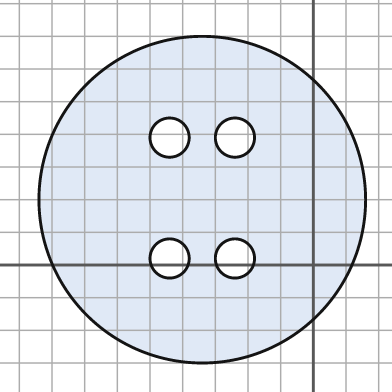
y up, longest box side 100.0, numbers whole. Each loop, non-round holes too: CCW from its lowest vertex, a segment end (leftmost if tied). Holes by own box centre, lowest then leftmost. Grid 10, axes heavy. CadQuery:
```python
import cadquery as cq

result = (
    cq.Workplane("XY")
    .moveTo(-34.0, 20.0)
    .circle(50.0)
    .moveTo(-44.0, 2.0)
    .circle(6.0)
    .moveTo(-24.0, 2.0)
    .circle(6.0)
    .moveTo(-44.0, 39.0)
    .circle(6.0)
    .moveTo(-24.0, 39.0)
    .circle(6.0)
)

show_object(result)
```